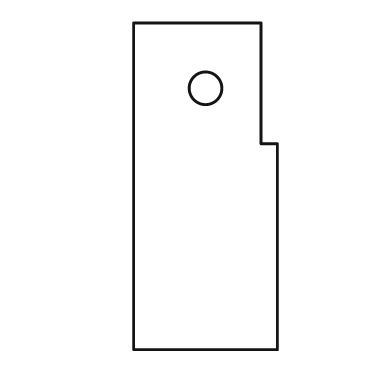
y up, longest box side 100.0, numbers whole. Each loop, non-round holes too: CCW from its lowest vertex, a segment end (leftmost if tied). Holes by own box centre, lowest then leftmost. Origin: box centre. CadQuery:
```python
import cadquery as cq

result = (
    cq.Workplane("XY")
    .moveTo(-22.0, -50.0)
    .lineTo(22.0, -50.0)
    .lineTo(22.0, 13.0)
    .lineTo(17.0, 13.0)
    .lineTo(17.0, 50.0)
    .lineTo(-22.0, 50.0)
    .close()
    .moveTo(0.0, 30.0)
    .circle(5.0)
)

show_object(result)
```